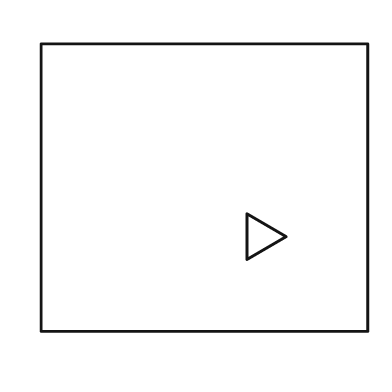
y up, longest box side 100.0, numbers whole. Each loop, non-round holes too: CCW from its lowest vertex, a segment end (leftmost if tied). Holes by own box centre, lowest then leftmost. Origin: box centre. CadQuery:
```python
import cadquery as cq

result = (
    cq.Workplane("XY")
    .moveTo(-50.0, -44.0)
    .lineTo(50.0, -44.0)
    .lineTo(50.0, 44.0)
    .lineTo(-50.0, 44.0)
    .close()
    .moveTo(13.0, -22.0)
    .lineTo(25.0, -15.0)
    .lineTo(13.0, -8.0)
    .close()
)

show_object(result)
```